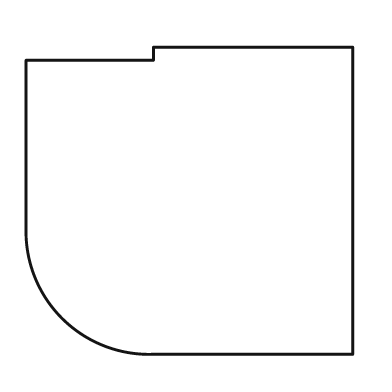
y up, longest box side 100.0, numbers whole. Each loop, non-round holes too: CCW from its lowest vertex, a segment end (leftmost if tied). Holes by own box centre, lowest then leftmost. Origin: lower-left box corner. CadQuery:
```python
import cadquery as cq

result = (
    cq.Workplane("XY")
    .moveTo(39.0, 0.0)
    .lineTo(100.0, 0.0)
    .lineTo(100.0, 94.0)
    .lineTo(39.0, 94.0)
    .lineTo(39.0, 90.0)
    .lineTo(0.0, 90.0)
    .lineTo(0.0, 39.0)
    .threePointArc((11.0, 11.0), (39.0, 0.0))
    .close()
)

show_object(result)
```